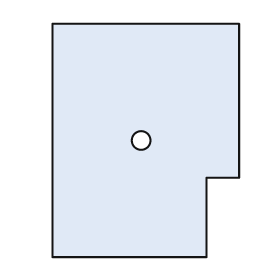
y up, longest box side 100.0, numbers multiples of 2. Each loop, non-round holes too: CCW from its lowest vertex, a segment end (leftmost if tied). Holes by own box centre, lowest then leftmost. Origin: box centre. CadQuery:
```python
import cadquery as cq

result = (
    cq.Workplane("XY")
    .moveTo(-40.0, -50.0)
    .lineTo(26.0, -50.0)
    .lineTo(26.0, -16.0)
    .lineTo(40.0, -16.0)
    .lineTo(40.0, 50.0)
    .lineTo(-40.0, 50.0)
    .close()
    .moveTo(-2.0, 0.0)
    .circle(4.0)
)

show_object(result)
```